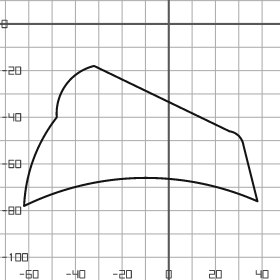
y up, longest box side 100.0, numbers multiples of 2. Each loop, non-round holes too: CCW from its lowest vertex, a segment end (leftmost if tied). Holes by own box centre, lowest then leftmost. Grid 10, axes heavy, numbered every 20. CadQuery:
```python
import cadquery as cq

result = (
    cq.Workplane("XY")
    .moveTo(-62.0, -78.0)
    .threePointArc((-12.0, -66.0), (38.0, -76.0))
    .lineTo(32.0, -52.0)
    .threePointArc((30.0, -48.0), (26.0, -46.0))
    .lineTo(-32.0, -18.0)
    .threePointArc((-44.0, -26.0), (-48.0, -40.0))
    .threePointArc((-58.0, -58.0), (-62.0, -78.0))
    .close()
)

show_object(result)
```